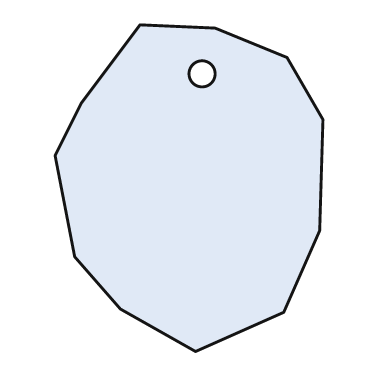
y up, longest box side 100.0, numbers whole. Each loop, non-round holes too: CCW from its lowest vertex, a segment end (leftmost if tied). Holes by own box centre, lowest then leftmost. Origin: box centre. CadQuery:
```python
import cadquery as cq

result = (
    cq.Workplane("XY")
    .moveTo(2.0, -50.0)
    .lineTo(29.0, -38.0)
    .lineTo(40.0, -13.0)
    .lineTo(41.0, 21.0)
    .lineTo(30.0, 40.0)
    .lineTo(8.0, 49.0)
    .lineTo(-15.0, 50.0)
    .lineTo(-33.0, 26.0)
    .lineTo(-41.0, 10.0)
    .lineTo(-35.0, -21.0)
    .lineTo(-21.0, -37.0)
    .close()
    .moveTo(4.0, 35.0)
    .circle(4.0)
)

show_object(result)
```